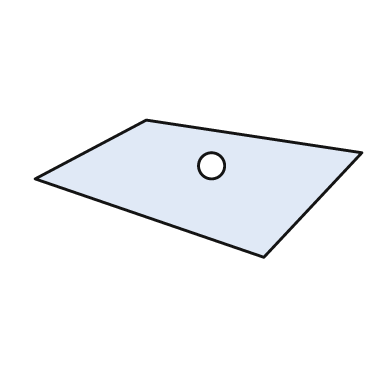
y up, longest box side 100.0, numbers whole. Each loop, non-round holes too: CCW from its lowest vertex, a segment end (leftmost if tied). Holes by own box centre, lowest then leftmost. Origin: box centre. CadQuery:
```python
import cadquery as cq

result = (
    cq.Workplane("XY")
    .moveTo(20.0, -21.0)
    .lineTo(50.0, 11.0)
    .lineTo(-16.0, 21.0)
    .lineTo(-50.0, 3.0)
    .close()
    .moveTo(4.0, 7.0)
    .circle(4.0)
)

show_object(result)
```